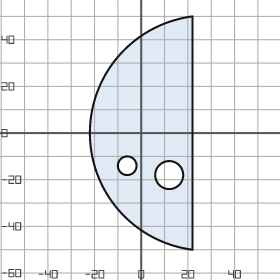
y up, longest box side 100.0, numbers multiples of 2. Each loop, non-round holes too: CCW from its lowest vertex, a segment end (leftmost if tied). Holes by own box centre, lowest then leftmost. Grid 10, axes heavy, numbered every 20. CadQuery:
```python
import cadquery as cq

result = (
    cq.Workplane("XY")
    .moveTo(22.0, -50.0)
    .lineTo(22.0, 50.0)
    .threePointArc((-22.0, 0.0), (22.0, -50.0))
    .close()
    .moveTo(12.0, -18.0)
    .circle(6.0)
    .moveTo(-6.0, -14.0)
    .circle(4.0)
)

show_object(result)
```